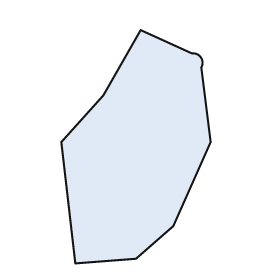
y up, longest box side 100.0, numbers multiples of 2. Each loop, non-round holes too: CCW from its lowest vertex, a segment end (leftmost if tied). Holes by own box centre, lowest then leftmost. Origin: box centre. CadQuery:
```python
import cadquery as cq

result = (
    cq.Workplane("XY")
    .moveTo(-26.0, -50.0)
    .lineTo(0.0, -48.0)
    .lineTo(16.0, -34.0)
    .lineTo(32.0, 2.0)
    .lineTo(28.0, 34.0)
    .threePointArc((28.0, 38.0), (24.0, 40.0))
    .lineTo(2.0, 50.0)
    .lineTo(-14.0, 22.0)
    .lineTo(-32.0, 2.0)
    .close()
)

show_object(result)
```